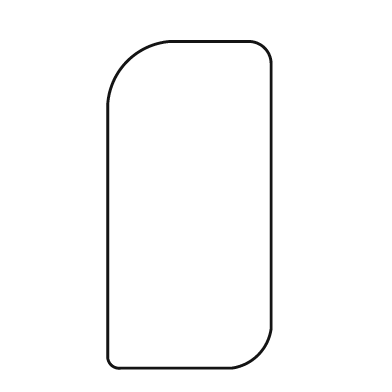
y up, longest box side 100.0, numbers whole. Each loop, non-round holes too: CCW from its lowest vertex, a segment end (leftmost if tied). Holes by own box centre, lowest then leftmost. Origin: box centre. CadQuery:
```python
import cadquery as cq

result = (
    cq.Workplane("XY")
    .moveTo(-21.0, -50.0)
    .lineTo(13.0, -50.0)
    .threePointArc((21.0, -46.0), (25.0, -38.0))
    .lineTo(25.0, 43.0)
    .threePointArc((23.0, 48.0), (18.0, 50.0))
    .lineTo(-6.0, 50.0)
    .threePointArc((-19.0, 44.0), (-25.0, 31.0))
    .lineTo(-25.0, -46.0)
    .threePointArc((-24.0, -49.0), (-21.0, -50.0))
    .close()
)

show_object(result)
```